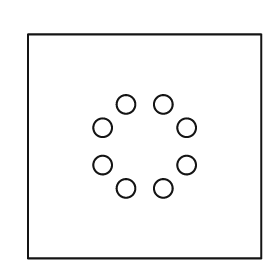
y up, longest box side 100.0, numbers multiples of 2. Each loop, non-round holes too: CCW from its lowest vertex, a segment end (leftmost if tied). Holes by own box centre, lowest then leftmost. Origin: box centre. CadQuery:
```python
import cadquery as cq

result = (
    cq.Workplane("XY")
    .moveTo(-50.0, -48.0)
    .lineTo(50.0, -48.0)
    .lineTo(50.0, 48.0)
    .lineTo(-50.0, 48.0)
    .close()
    .moveTo(-8.0, -18.0)
    .circle(4.0)
    .moveTo(8.0, -18.0)
    .circle(4.0)
    .moveTo(-18.0, -8.0)
    .circle(4.0)
    .moveTo(18.0, -8.0)
    .circle(4.0)
    .moveTo(-18.0, 8.0)
    .circle(4.0)
    .moveTo(18.0, 8.0)
    .circle(4.0)
    .moveTo(-8.0, 18.0)
    .circle(4.0)
    .moveTo(8.0, 18.0)
    .circle(4.0)
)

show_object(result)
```